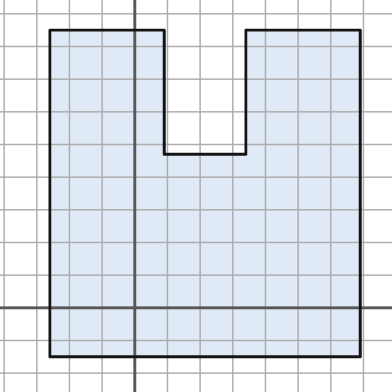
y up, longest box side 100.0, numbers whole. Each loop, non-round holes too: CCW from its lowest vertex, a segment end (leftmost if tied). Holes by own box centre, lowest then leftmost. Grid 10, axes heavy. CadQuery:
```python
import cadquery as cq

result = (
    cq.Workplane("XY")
    .moveTo(-26.0, -15.0)
    .lineTo(69.0, -15.0)
    .lineTo(69.0, 85.0)
    .lineTo(34.0, 85.0)
    .lineTo(34.0, 47.0)
    .lineTo(9.0, 47.0)
    .lineTo(9.0, 85.0)
    .lineTo(-26.0, 85.0)
    .close()
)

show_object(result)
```